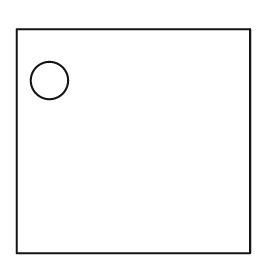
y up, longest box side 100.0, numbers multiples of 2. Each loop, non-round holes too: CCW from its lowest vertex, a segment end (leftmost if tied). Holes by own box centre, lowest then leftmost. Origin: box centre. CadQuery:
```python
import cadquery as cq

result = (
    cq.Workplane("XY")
    .moveTo(-50.0, -48.0)
    .lineTo(50.0, -48.0)
    .lineTo(50.0, 48.0)
    .lineTo(-50.0, 48.0)
    .close()
    .moveTo(-36.0, 26.0)
    .circle(8.0)
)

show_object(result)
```